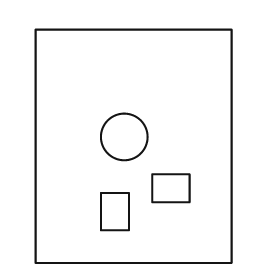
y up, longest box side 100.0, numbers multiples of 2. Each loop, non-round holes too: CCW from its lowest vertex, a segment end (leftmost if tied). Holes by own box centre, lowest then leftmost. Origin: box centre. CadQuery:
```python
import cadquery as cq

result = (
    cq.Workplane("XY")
    .moveTo(-42.0, -50.0)
    .lineTo(42.0, -50.0)
    .lineTo(42.0, 50.0)
    .lineTo(-42.0, 50.0)
    .close()
    .moveTo(-14.0, -36.0)
    .lineTo(-2.0, -36.0)
    .lineTo(-2.0, -20.0)
    .lineTo(-14.0, -20.0)
    .close()
    .moveTo(8.0, -24.0)
    .lineTo(24.0, -24.0)
    .lineTo(24.0, -12.0)
    .lineTo(8.0, -12.0)
    .close()
    .moveTo(-4.0, 4.0)
    .circle(10.0)
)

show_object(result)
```